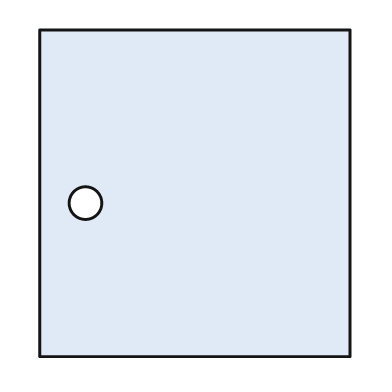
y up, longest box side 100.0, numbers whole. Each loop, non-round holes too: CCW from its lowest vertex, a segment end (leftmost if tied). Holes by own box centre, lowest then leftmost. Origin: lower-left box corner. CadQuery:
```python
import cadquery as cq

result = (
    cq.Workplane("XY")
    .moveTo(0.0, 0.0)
    .lineTo(95.0, 0.0)
    .lineTo(95.0, 100.0)
    .lineTo(0.0, 100.0)
    .close()
    .moveTo(14.0, 47.0)
    .circle(5.0)
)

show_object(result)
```